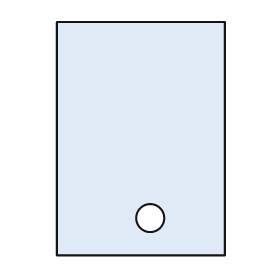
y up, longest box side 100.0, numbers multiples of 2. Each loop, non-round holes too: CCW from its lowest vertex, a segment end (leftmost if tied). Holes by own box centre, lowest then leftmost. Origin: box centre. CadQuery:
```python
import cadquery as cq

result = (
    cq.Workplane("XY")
    .moveTo(-36.0, -50.0)
    .lineTo(36.0, -50.0)
    .lineTo(36.0, 50.0)
    .lineTo(-36.0, 50.0)
    .close()
    .moveTo(4.0, -34.0)
    .circle(6.0)
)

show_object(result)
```